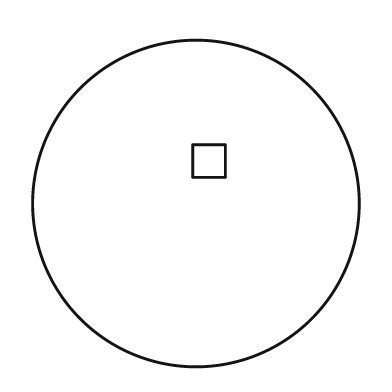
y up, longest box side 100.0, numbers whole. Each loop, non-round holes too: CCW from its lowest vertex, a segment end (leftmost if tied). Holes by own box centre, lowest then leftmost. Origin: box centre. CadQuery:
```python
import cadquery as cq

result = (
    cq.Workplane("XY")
    .moveTo(0.0, 0.0)
    .circle(50.0)
    .moveTo(-1.0, 8.0)
    .lineTo(9.0, 8.0)
    .lineTo(9.0, 18.0)
    .lineTo(-1.0, 18.0)
    .close()
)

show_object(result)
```